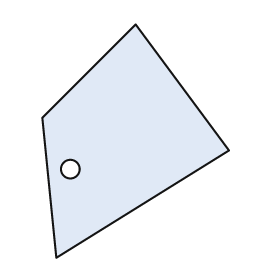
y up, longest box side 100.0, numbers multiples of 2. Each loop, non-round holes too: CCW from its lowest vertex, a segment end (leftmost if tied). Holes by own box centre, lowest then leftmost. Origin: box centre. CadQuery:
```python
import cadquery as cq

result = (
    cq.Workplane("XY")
    .moveTo(-34.0, -50.0)
    .lineTo(40.0, -4.0)
    .lineTo(0.0, 50.0)
    .lineTo(-40.0, 10.0)
    .close()
    .moveTo(-28.0, -12.0)
    .circle(4.0)
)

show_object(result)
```